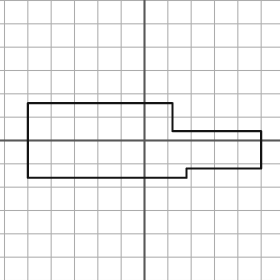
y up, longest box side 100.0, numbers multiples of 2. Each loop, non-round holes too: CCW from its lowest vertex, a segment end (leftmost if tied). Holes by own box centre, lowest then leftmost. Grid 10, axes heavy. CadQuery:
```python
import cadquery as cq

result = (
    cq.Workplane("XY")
    .moveTo(-50.0, -16.0)
    .lineTo(18.0, -16.0)
    .lineTo(18.0, -12.0)
    .lineTo(50.0, -12.0)
    .lineTo(50.0, 4.0)
    .lineTo(12.0, 4.0)
    .lineTo(12.0, 16.0)
    .lineTo(-50.0, 16.0)
    .close()
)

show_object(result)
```